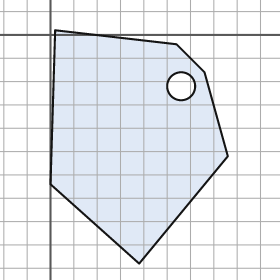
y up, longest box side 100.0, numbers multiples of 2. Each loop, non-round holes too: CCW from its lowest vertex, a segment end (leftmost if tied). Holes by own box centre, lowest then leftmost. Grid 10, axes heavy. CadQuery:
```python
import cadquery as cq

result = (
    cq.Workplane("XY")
    .moveTo(38.0, -98.0)
    .lineTo(76.0, -52.0)
    .lineTo(66.0, -16.0)
    .lineTo(54.0, -4.0)
    .lineTo(2.0, 2.0)
    .lineTo(0.0, -64.0)
    .close()
    .moveTo(56.0, -22.0)
    .circle(6.0)
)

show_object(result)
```